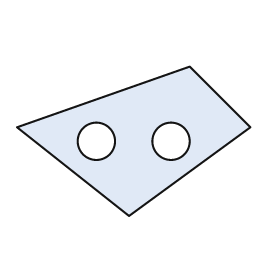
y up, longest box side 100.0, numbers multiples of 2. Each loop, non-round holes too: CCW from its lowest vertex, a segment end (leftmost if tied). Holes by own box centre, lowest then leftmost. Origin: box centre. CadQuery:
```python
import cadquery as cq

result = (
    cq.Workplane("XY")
    .moveTo(-2.0, -32.0)
    .lineTo(50.0, 6.0)
    .lineTo(24.0, 32.0)
    .lineTo(-50.0, 6.0)
    .close()
    .moveTo(-16.0, 0.0)
    .circle(8.0)
    .moveTo(16.0, 0.0)
    .circle(8.0)
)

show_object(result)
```